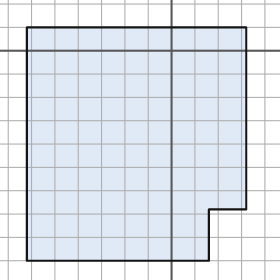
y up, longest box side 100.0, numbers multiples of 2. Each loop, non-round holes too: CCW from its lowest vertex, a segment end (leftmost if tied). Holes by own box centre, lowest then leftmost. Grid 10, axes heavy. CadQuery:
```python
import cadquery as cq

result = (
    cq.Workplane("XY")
    .moveTo(-62.0, -90.0)
    .lineTo(16.0, -90.0)
    .lineTo(16.0, -68.0)
    .lineTo(32.0, -68.0)
    .lineTo(32.0, 10.0)
    .lineTo(-62.0, 10.0)
    .close()
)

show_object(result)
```